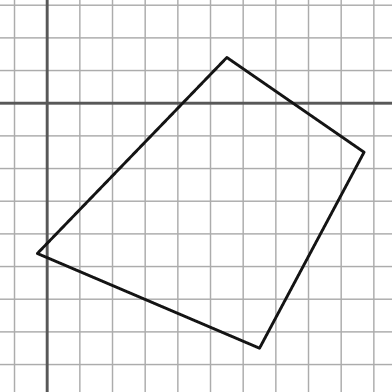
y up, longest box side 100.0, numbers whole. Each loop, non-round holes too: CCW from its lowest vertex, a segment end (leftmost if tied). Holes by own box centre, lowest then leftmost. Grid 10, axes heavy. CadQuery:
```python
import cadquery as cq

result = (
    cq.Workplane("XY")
    .moveTo(65.0, -75.0)
    .lineTo(97.0, -15.0)
    .lineTo(55.0, 14.0)
    .lineTo(-3.0, -46.0)
    .close()
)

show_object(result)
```